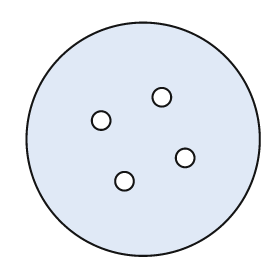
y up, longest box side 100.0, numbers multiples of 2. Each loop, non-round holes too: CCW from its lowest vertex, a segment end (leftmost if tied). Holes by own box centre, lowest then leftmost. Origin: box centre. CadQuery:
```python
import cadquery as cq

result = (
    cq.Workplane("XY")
    .moveTo(0.0, 0.0)
    .circle(50.0)
    .moveTo(-8.0, -18.0)
    .circle(4.0)
    .moveTo(18.0, -8.0)
    .circle(4.0)
    .moveTo(-18.0, 8.0)
    .circle(4.0)
    .moveTo(8.0, 18.0)
    .circle(4.0)
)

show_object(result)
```